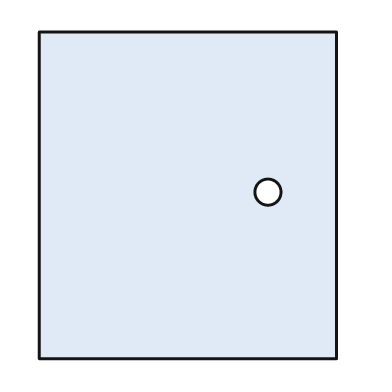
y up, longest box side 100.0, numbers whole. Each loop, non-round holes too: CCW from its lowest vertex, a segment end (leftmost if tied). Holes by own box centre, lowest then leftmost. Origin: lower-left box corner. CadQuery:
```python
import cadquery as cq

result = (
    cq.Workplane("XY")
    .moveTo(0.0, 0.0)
    .lineTo(91.0, 0.0)
    .lineTo(91.0, 100.0)
    .lineTo(0.0, 100.0)
    .close()
    .moveTo(70.0, 51.0)
    .circle(4.0)
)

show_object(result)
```